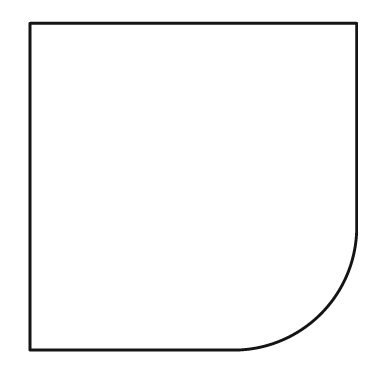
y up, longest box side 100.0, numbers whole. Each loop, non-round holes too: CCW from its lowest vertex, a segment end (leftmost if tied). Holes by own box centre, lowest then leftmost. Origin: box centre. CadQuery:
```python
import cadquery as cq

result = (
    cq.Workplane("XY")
    .moveTo(-50.0, -50.0)
    .lineTo(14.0, -50.0)
    .threePointArc((39.0, -39.0), (50.0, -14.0))
    .lineTo(50.0, 50.0)
    .lineTo(-50.0, 50.0)
    .close()
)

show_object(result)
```